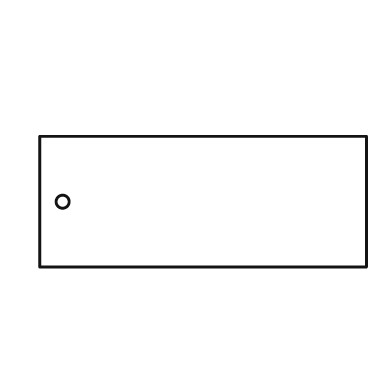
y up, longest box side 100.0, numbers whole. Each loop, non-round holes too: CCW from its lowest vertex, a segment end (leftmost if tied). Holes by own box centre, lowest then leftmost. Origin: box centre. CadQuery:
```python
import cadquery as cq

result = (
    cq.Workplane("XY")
    .moveTo(-50.0, -20.0)
    .lineTo(50.0, -20.0)
    .lineTo(50.0, 20.0)
    .lineTo(-50.0, 20.0)
    .close()
    .moveTo(-43.0, 0.0)
    .circle(2.0)
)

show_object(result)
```